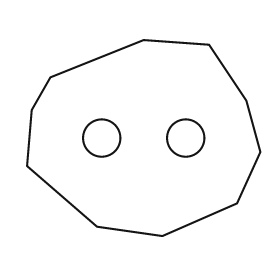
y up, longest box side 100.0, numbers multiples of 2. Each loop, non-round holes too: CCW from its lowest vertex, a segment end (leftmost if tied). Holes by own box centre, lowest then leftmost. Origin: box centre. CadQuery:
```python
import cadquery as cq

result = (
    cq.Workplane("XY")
    .moveTo(8.0, -42.0)
    .lineTo(40.0, -28.0)
    .lineTo(50.0, -6.0)
    .lineTo(44.0, 16.0)
    .lineTo(28.0, 40.0)
    .lineTo(0.0, 42.0)
    .lineTo(-40.0, 26.0)
    .lineTo(-48.0, 12.0)
    .lineTo(-50.0, -12.0)
    .lineTo(-20.0, -38.0)
    .close()
    .moveTo(-18.0, 0.0)
    .circle(8.0)
    .moveTo(18.0, 0.0)
    .circle(8.0)
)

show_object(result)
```